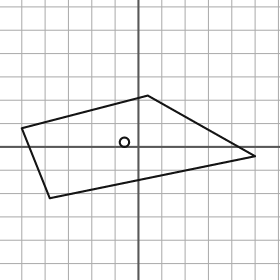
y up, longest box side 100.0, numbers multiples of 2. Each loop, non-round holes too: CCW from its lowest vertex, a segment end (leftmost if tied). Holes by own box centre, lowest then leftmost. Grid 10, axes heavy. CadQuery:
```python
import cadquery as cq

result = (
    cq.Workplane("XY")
    .moveTo(-38.0, -22.0)
    .lineTo(50.0, -4.0)
    .lineTo(4.0, 22.0)
    .lineTo(-50.0, 8.0)
    .close()
    .moveTo(-6.0, 2.0)
    .circle(2.0)
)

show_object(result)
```